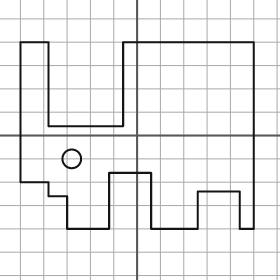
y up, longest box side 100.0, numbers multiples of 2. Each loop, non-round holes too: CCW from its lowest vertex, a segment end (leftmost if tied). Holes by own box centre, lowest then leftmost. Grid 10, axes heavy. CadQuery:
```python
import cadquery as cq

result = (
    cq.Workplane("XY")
    .moveTo(-30.0, -40.0)
    .lineTo(-12.0, -40.0)
    .lineTo(-12.0, -16.0)
    .lineTo(6.0, -16.0)
    .lineTo(6.0, -40.0)
    .lineTo(26.0, -40.0)
    .lineTo(26.0, -24.0)
    .lineTo(44.0, -24.0)
    .lineTo(44.0, -40.0)
    .lineTo(50.0, -40.0)
    .lineTo(50.0, 40.0)
    .lineTo(-6.0, 40.0)
    .lineTo(-6.0, 4.0)
    .lineTo(-38.0, 4.0)
    .lineTo(-38.0, 40.0)
    .lineTo(-50.0, 40.0)
    .lineTo(-50.0, -20.0)
    .lineTo(-38.0, -20.0)
    .lineTo(-38.0, -26.0)
    .lineTo(-30.0, -26.0)
    .close()
    .moveTo(-28.0, -10.0)
    .circle(4.0)
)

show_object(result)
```